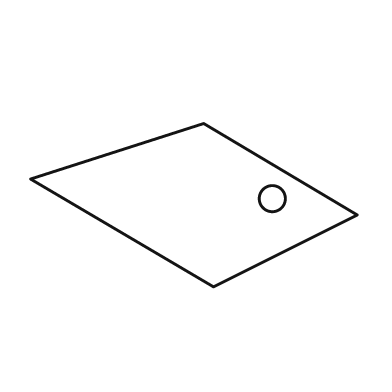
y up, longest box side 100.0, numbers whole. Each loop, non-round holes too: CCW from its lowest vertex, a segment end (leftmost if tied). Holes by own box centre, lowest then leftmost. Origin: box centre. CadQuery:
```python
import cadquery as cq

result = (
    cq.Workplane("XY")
    .moveTo(6.0, -25.0)
    .lineTo(50.0, -3.0)
    .lineTo(3.0, 25.0)
    .lineTo(-50.0, 8.0)
    .close()
    .moveTo(24.0, 2.0)
    .circle(4.0)
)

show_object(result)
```